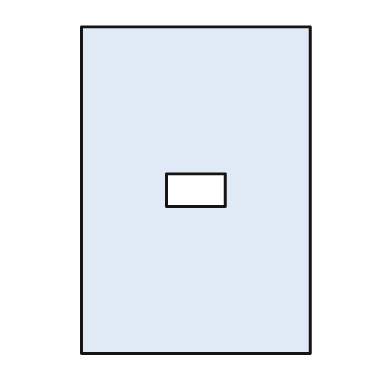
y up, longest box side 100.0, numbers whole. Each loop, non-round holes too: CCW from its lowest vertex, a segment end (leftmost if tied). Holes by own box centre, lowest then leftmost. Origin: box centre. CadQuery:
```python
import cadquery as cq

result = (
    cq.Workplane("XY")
    .moveTo(-35.0, -50.0)
    .lineTo(35.0, -50.0)
    .lineTo(35.0, 50.0)
    .lineTo(-35.0, 50.0)
    .close()
    .moveTo(-9.0, -5.0)
    .lineTo(9.0, -5.0)
    .lineTo(9.0, 5.0)
    .lineTo(-9.0, 5.0)
    .close()
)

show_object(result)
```